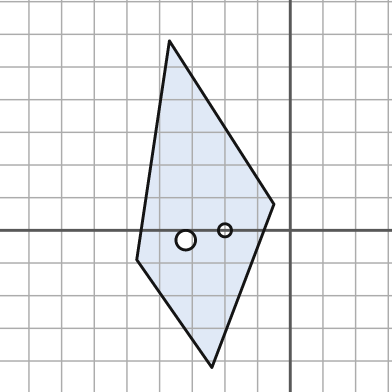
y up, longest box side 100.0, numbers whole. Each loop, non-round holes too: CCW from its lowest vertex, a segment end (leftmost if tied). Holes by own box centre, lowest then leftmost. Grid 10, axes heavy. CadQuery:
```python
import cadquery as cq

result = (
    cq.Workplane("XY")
    .moveTo(-24.0, -42.0)
    .lineTo(-5.0, 8.0)
    .lineTo(-37.0, 58.0)
    .lineTo(-47.0, -9.0)
    .close()
    .moveTo(-32.0, -3.0)
    .circle(3.0)
    .moveTo(-20.0, 0.0)
    .circle(2.0)
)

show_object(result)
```